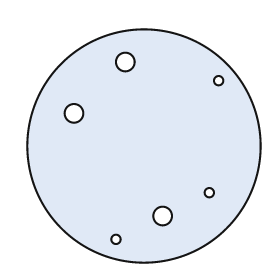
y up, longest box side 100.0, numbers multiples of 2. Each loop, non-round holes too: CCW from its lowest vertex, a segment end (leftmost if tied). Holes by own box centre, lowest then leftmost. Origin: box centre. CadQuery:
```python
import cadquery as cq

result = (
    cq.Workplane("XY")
    .moveTo(0.0, 0.0)
    .circle(50.0)
    .moveTo(-12.0, -40.0)
    .circle(2.0)
    .moveTo(8.0, -30.0)
    .circle(4.0)
    .moveTo(28.0, -20.0)
    .circle(2.0)
    .moveTo(-30.0, 14.0)
    .circle(4.0)
    .moveTo(32.0, 28.0)
    .circle(2.0)
    .moveTo(-8.0, 36.0)
    .circle(4.0)
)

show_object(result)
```